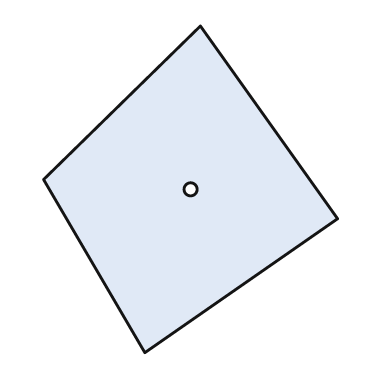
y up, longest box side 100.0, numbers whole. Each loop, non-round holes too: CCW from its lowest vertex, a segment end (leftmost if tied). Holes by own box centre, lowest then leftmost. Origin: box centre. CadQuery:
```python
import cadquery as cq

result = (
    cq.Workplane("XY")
    .moveTo(-14.0, -50.0)
    .lineTo(45.0, -9.0)
    .lineTo(3.0, 50.0)
    .lineTo(-45.0, 3.0)
    .close()
    .moveTo(0.0, 0.0)
    .circle(2.0)
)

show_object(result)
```